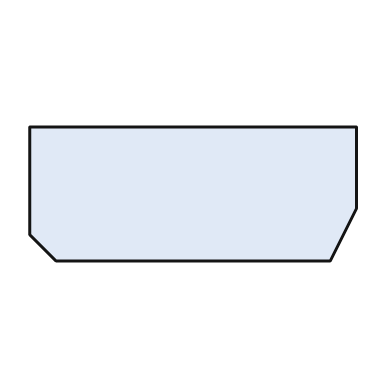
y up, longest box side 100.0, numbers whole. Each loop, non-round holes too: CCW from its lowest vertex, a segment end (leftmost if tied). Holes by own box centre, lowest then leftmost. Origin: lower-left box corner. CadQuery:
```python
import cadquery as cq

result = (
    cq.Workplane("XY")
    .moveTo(8.0, 0.0)
    .lineTo(92.0, 0.0)
    .lineTo(100.0, 16.0)
    .lineTo(100.0, 41.0)
    .lineTo(0.0, 41.0)
    .lineTo(0.0, 8.0)
    .close()
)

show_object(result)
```